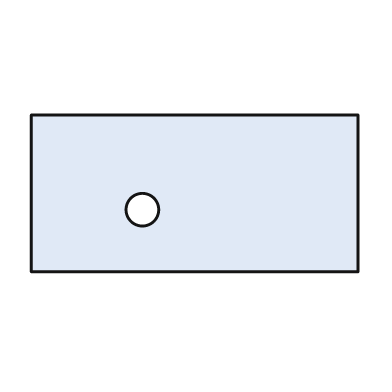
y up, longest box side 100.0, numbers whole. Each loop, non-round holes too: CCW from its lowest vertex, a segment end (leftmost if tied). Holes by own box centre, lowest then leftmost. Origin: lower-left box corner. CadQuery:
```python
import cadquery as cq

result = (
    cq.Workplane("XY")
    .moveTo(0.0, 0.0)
    .lineTo(100.0, 0.0)
    .lineTo(100.0, 48.0)
    .lineTo(0.0, 48.0)
    .close()
    .moveTo(34.0, 19.0)
    .circle(5.0)
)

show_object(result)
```